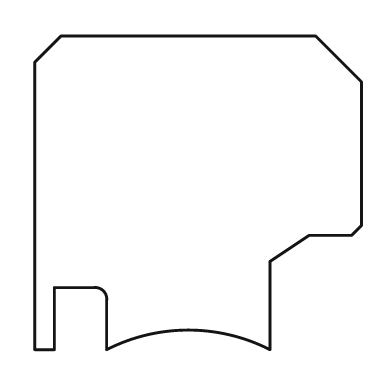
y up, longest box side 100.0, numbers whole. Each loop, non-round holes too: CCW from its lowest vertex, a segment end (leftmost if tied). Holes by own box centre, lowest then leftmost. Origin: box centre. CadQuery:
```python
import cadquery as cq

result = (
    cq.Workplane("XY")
    .moveTo(-50.0, -48.0)
    .lineTo(-44.0, -48.0)
    .lineTo(-44.0, -29.0)
    .lineTo(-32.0, -29.0)
    .threePointArc((-29.0, -30.0), (-28.0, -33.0))
    .lineTo(-28.0, -48.0)
    .threePointArc((-3.0, -42.0), (22.0, -48.0))
    .lineTo(22.0, -21.0)
    .lineTo(34.0, -13.0)
    .lineTo(47.0, -13.0)
    .lineTo(50.0, -10.0)
    .lineTo(50.0, 34.0)
    .lineTo(36.0, 48.0)
    .lineTo(-42.0, 48.0)
    .lineTo(-50.0, 40.0)
    .close()
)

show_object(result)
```